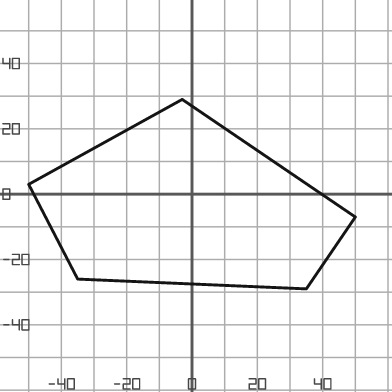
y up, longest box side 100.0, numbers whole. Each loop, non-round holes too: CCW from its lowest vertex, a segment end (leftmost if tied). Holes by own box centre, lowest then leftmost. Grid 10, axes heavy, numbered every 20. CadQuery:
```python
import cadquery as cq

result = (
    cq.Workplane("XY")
    .moveTo(35.0, -29.0)
    .lineTo(50.0, -7.0)
    .lineTo(-3.0, 29.0)
    .lineTo(-50.0, 3.0)
    .lineTo(-35.0, -26.0)
    .close()
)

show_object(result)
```